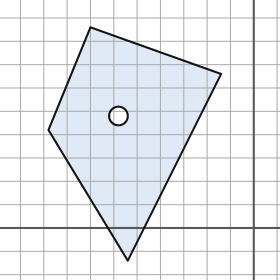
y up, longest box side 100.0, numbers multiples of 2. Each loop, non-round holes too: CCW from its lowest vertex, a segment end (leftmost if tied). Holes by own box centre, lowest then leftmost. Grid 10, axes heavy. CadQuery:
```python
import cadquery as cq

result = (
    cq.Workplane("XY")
    .moveTo(-54.0, -14.0)
    .lineTo(-14.0, 66.0)
    .lineTo(-70.0, 86.0)
    .lineTo(-88.0, 42.0)
    .close()
    .moveTo(-58.0, 48.0)
    .circle(4.0)
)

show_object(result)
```